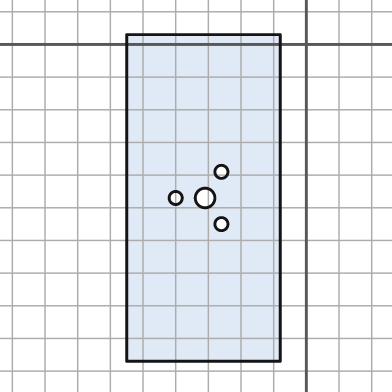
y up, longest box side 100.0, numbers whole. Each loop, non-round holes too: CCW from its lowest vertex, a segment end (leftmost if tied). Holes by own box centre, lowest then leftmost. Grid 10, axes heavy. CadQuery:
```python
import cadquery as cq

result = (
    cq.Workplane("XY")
    .moveTo(-55.0, -97.0)
    .lineTo(-8.0, -97.0)
    .lineTo(-8.0, 3.0)
    .lineTo(-55.0, 3.0)
    .close()
    .moveTo(-26.0, -55.0)
    .circle(2.0)
    .moveTo(-40.0, -47.0)
    .circle(2.0)
    .moveTo(-31.0, -47.0)
    .circle(3.0)
    .moveTo(-26.0, -39.0)
    .circle(2.0)
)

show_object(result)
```